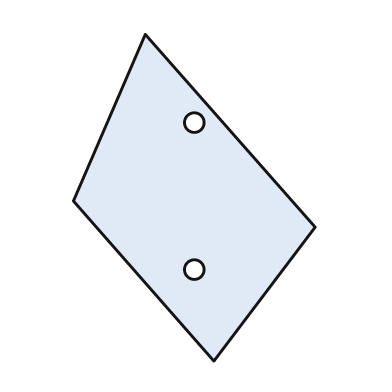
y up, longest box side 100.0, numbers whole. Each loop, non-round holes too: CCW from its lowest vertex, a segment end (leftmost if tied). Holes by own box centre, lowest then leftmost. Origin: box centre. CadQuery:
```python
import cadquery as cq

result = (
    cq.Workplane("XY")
    .moveTo(6.0, -50.0)
    .lineTo(37.0, -9.0)
    .lineTo(-15.0, 50.0)
    .lineTo(-37.0, -1.0)
    .close()
    .moveTo(0.0, -22.0)
    .circle(3.0)
    .moveTo(0.0, 23.0)
    .circle(3.0)
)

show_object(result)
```